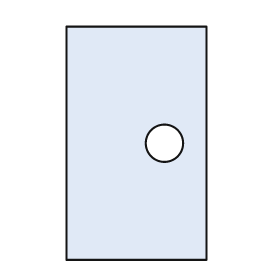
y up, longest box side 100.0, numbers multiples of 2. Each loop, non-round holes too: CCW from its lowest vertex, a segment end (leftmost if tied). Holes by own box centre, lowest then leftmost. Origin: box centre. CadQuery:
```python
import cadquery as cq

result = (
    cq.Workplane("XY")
    .moveTo(-30.0, -50.0)
    .lineTo(30.0, -50.0)
    .lineTo(30.0, 50.0)
    .lineTo(-30.0, 50.0)
    .close()
    .moveTo(12.0, 0.0)
    .circle(8.0)
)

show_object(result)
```